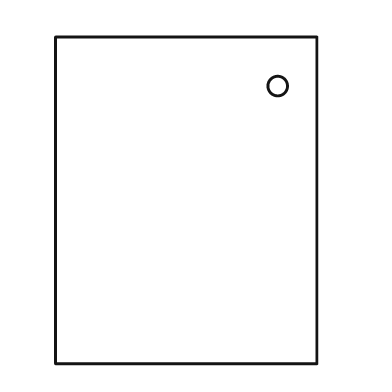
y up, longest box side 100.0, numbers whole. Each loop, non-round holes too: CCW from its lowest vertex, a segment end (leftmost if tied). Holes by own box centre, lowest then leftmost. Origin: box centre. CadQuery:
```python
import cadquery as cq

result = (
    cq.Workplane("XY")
    .moveTo(-40.0, -50.0)
    .lineTo(40.0, -50.0)
    .lineTo(40.0, 50.0)
    .lineTo(-40.0, 50.0)
    .close()
    .moveTo(28.0, 35.0)
    .circle(3.0)
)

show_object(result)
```